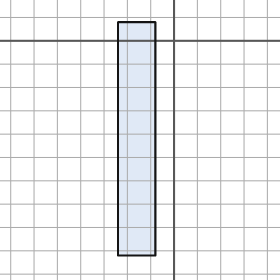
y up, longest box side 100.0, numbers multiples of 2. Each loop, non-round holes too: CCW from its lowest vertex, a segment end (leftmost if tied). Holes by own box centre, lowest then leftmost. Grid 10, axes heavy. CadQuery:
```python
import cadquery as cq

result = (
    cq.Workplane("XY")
    .moveTo(-24.0, -92.0)
    .lineTo(-8.0, -92.0)
    .lineTo(-8.0, 8.0)
    .lineTo(-24.0, 8.0)
    .close()
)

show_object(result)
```